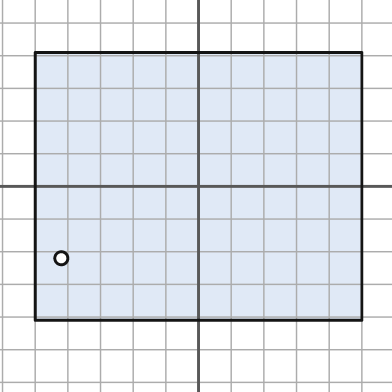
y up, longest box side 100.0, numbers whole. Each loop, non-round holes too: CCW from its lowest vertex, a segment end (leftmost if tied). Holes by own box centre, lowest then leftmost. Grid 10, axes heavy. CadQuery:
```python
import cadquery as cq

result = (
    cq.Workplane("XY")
    .moveTo(-50.0, -41.0)
    .lineTo(50.0, -41.0)
    .lineTo(50.0, 41.0)
    .lineTo(-50.0, 41.0)
    .close()
    .moveTo(-42.0, -22.0)
    .circle(2.0)
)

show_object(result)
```